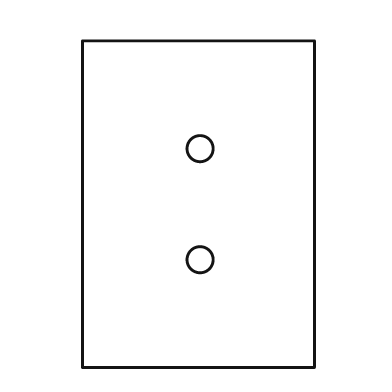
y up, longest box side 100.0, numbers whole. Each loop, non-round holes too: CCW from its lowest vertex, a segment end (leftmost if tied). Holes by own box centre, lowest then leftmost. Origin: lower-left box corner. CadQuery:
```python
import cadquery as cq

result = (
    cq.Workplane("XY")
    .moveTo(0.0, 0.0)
    .lineTo(71.0, 0.0)
    .lineTo(71.0, 100.0)
    .lineTo(0.0, 100.0)
    .close()
    .moveTo(36.0, 33.0)
    .circle(4.0)
    .moveTo(36.0, 67.0)
    .circle(4.0)
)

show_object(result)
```